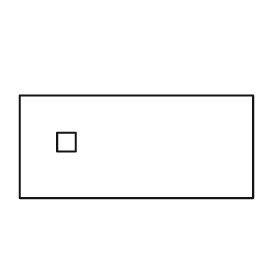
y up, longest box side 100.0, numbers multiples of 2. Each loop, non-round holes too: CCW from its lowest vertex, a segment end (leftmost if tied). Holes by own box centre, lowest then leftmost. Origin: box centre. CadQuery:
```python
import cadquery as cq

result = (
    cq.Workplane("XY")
    .moveTo(-50.0, -22.0)
    .lineTo(50.0, -22.0)
    .lineTo(50.0, 22.0)
    .lineTo(-50.0, 22.0)
    .close()
    .moveTo(-34.0, -2.0)
    .lineTo(-26.0, -2.0)
    .lineTo(-26.0, 6.0)
    .lineTo(-34.0, 6.0)
    .close()
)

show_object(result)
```